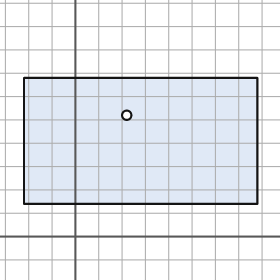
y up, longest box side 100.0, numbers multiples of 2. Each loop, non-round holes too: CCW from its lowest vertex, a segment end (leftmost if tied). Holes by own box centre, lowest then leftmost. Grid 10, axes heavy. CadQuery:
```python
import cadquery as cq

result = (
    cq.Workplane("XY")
    .moveTo(-22.0, 14.0)
    .lineTo(78.0, 14.0)
    .lineTo(78.0, 68.0)
    .lineTo(-22.0, 68.0)
    .close()
    .moveTo(22.0, 52.0)
    .circle(2.0)
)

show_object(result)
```